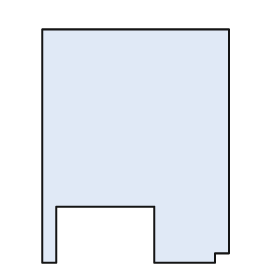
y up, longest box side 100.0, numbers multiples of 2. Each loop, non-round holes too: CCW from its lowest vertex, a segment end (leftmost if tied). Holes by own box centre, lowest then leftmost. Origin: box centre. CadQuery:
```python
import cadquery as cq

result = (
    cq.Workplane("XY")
    .moveTo(-40.0, -50.0)
    .lineTo(-34.0, -50.0)
    .lineTo(-34.0, -26.0)
    .lineTo(8.0, -26.0)
    .lineTo(8.0, -50.0)
    .lineTo(34.0, -50.0)
    .lineTo(34.0, -46.0)
    .lineTo(40.0, -46.0)
    .lineTo(40.0, 50.0)
    .lineTo(-40.0, 50.0)
    .close()
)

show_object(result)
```